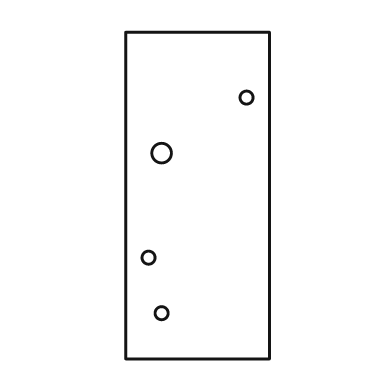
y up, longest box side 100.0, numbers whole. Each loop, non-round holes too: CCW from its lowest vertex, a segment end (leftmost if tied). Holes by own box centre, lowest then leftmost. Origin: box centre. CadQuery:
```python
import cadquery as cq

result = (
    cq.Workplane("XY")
    .moveTo(-22.0, -50.0)
    .lineTo(22.0, -50.0)
    .lineTo(22.0, 50.0)
    .lineTo(-22.0, 50.0)
    .close()
    .moveTo(-11.0, -36.0)
    .circle(2.0)
    .moveTo(-15.0, -19.0)
    .circle(2.0)
    .moveTo(-11.0, 13.0)
    .circle(3.0)
    .moveTo(15.0, 30.0)
    .circle(2.0)
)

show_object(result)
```